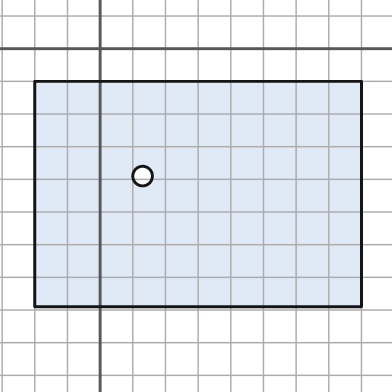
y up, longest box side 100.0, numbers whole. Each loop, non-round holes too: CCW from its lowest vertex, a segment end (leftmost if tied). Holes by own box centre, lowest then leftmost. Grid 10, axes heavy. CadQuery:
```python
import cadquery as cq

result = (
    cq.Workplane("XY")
    .moveTo(-20.0, -79.0)
    .lineTo(80.0, -79.0)
    .lineTo(80.0, -10.0)
    .lineTo(-20.0, -10.0)
    .close()
    .moveTo(13.0, -39.0)
    .circle(3.0)
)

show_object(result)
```